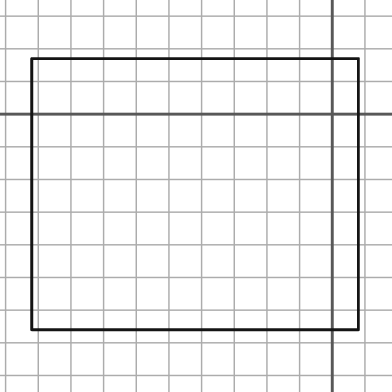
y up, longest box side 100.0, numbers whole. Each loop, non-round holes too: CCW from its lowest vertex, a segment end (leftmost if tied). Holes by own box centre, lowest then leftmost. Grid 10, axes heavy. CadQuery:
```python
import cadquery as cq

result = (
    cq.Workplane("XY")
    .moveTo(-92.0, -66.0)
    .lineTo(8.0, -66.0)
    .lineTo(8.0, 17.0)
    .lineTo(-92.0, 17.0)
    .close()
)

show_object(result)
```